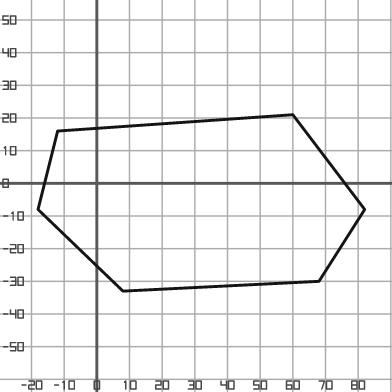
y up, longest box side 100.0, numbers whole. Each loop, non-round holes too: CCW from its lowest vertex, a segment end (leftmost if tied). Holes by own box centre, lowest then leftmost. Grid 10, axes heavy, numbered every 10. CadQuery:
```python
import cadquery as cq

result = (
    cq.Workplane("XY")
    .moveTo(8.0, -33.0)
    .lineTo(68.0, -30.0)
    .lineTo(82.0, -8.0)
    .lineTo(60.0, 21.0)
    .lineTo(-12.0, 16.0)
    .lineTo(-18.0, -8.0)
    .close()
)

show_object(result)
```